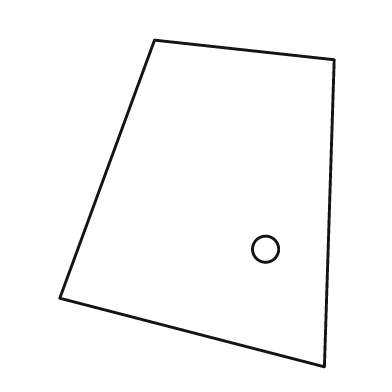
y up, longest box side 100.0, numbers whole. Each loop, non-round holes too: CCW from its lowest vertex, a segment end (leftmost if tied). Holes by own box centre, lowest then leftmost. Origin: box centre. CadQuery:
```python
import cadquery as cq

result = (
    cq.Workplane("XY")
    .moveTo(39.0, -50.0)
    .lineTo(42.0, 44.0)
    .lineTo(-13.0, 50.0)
    .lineTo(-42.0, -29.0)
    .close()
    .moveTo(21.0, -14.0)
    .circle(4.0)
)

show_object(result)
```